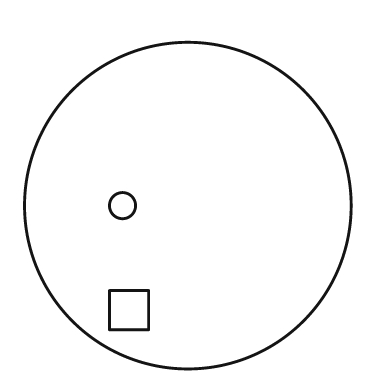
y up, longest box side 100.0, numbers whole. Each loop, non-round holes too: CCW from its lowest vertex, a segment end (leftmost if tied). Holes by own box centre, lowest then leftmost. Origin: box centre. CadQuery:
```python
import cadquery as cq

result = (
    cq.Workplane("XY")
    .moveTo(0.0, 0.0)
    .circle(50.0)
    .moveTo(-24.0, -38.0)
    .lineTo(-12.0, -38.0)
    .lineTo(-12.0, -26.0)
    .lineTo(-24.0, -26.0)
    .close()
    .moveTo(-20.0, 0.0)
    .circle(4.0)
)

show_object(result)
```